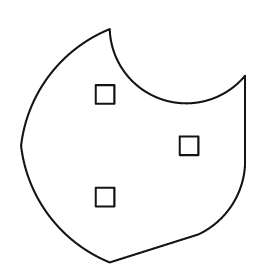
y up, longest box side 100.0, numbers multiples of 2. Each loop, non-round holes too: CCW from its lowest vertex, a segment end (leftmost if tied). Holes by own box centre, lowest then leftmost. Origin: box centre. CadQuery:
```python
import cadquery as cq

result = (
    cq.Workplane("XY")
    .moveTo(-10.0, -50.0)
    .lineTo(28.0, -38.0)
    .threePointArc((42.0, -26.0), (48.0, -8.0))
    .lineTo(48.0, 30.0)
    .threePointArc((12.0, 20.0), (-10.0, 50.0))
    .threePointArc((-36.0, 30.0), (-48.0, 0.0))
    .threePointArc((-36.0, -30.0), (-10.0, -50.0))
    .close()
    .moveTo(-16.0, -26.0)
    .lineTo(-8.0, -26.0)
    .lineTo(-8.0, -18.0)
    .lineTo(-16.0, -18.0)
    .close()
    .moveTo(20.0, -4.0)
    .lineTo(28.0, -4.0)
    .lineTo(28.0, 4.0)
    .lineTo(20.0, 4.0)
    .close()
    .moveTo(-16.0, 18.0)
    .lineTo(-8.0, 18.0)
    .lineTo(-8.0, 26.0)
    .lineTo(-16.0, 26.0)
    .close()
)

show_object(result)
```